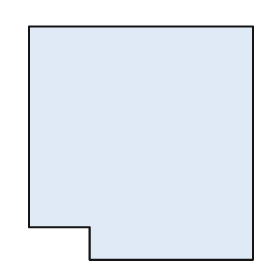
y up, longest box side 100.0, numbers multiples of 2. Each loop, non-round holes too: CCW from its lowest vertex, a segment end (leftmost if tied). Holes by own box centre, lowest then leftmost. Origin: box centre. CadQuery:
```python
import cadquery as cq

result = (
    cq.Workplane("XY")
    .moveTo(-22.0, -50.0)
    .lineTo(48.0, -50.0)
    .lineTo(48.0, 50.0)
    .lineTo(-48.0, 50.0)
    .lineTo(-48.0, -36.0)
    .lineTo(-22.0, -36.0)
    .close()
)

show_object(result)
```